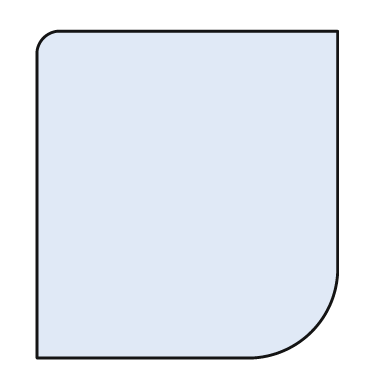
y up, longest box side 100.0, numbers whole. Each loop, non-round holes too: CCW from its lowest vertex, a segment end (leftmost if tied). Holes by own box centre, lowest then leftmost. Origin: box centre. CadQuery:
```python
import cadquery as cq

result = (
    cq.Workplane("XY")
    .moveTo(-46.0, -50.0)
    .lineTo(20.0, -50.0)
    .threePointArc((38.0, -42.0), (46.0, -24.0))
    .lineTo(46.0, 50.0)
    .lineTo(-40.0, 50.0)
    .threePointArc((-44.0, 48.0), (-46.0, 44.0))
    .close()
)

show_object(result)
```